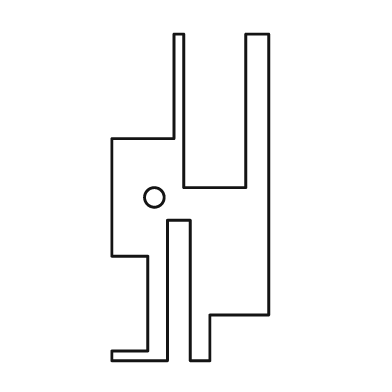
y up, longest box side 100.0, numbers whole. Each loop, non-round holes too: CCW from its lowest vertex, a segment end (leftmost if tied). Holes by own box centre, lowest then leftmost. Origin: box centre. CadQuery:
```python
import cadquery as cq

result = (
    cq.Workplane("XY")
    .moveTo(-24.0, -50.0)
    .lineTo(-7.0, -50.0)
    .lineTo(-7.0, -7.0)
    .lineTo(0.0, -7.0)
    .lineTo(0.0, -50.0)
    .lineTo(6.0, -50.0)
    .lineTo(6.0, -36.0)
    .lineTo(24.0, -36.0)
    .lineTo(24.0, 50.0)
    .lineTo(17.0, 50.0)
    .lineTo(17.0, 3.0)
    .lineTo(-2.0, 3.0)
    .lineTo(-2.0, 50.0)
    .lineTo(-5.0, 50.0)
    .lineTo(-5.0, 18.0)
    .lineTo(-24.0, 18.0)
    .lineTo(-24.0, -18.0)
    .lineTo(-13.0, -18.0)
    .lineTo(-13.0, -47.0)
    .lineTo(-24.0, -47.0)
    .close()
    .moveTo(-11.0, 0.0)
    .circle(3.0)
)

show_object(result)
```